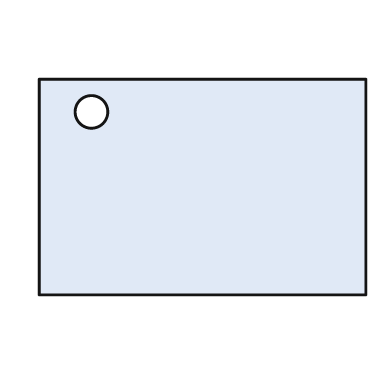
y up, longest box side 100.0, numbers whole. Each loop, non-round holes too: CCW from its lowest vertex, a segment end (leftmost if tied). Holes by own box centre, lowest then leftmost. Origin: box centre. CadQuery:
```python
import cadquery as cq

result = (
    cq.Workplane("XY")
    .moveTo(-50.0, -33.0)
    .lineTo(50.0, -33.0)
    .lineTo(50.0, 33.0)
    .lineTo(-50.0, 33.0)
    .close()
    .moveTo(-34.0, 23.0)
    .circle(5.0)
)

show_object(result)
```